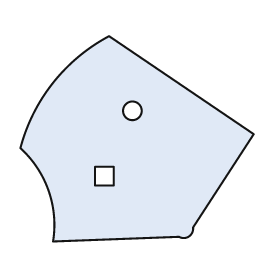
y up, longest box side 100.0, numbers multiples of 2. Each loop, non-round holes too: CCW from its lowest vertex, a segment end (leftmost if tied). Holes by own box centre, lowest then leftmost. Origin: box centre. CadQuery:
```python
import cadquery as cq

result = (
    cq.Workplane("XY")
    .moveTo(-36.0, -44.0)
    .lineTo(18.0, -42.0)
    .threePointArc((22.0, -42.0), (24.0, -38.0))
    .lineTo(50.0, 2.0)
    .lineTo(-12.0, 44.0)
    .threePointArc((-36.0, 24.0), (-50.0, -4.0))
    .threePointArc((-38.0, -22.0), (-36.0, -44.0))
    .close()
    .moveTo(-18.0, -20.0)
    .lineTo(-10.0, -20.0)
    .lineTo(-10.0, -12.0)
    .lineTo(-18.0, -12.0)
    .close()
    .moveTo(-2.0, 12.0)
    .circle(4.0)
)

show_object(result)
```